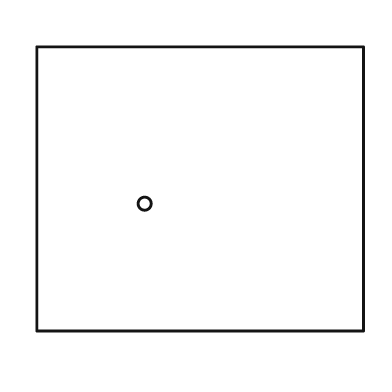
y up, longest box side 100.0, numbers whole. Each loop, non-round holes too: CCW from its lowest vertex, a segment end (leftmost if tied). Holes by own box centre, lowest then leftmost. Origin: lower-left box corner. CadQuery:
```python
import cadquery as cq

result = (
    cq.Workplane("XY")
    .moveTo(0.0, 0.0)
    .lineTo(100.0, 0.0)
    .lineTo(100.0, 87.0)
    .lineTo(0.0, 87.0)
    .close()
    .moveTo(33.0, 39.0)
    .circle(2.0)
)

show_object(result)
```